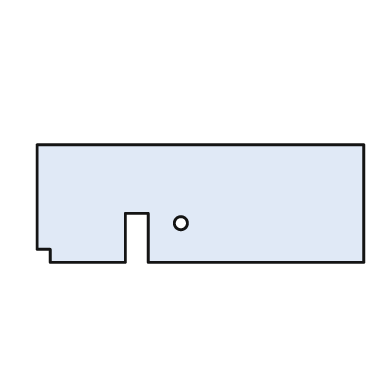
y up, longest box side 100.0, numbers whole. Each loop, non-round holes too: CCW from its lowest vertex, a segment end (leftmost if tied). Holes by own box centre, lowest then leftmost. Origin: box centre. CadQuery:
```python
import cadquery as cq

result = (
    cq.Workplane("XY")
    .moveTo(-46.0, -18.0)
    .lineTo(-23.0, -18.0)
    .lineTo(-23.0, -3.0)
    .lineTo(-16.0, -3.0)
    .lineTo(-16.0, -18.0)
    .lineTo(50.0, -18.0)
    .lineTo(50.0, 18.0)
    .lineTo(-50.0, 18.0)
    .lineTo(-50.0, -14.0)
    .lineTo(-46.0, -14.0)
    .close()
    .moveTo(-6.0, -6.0)
    .circle(2.0)
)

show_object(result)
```